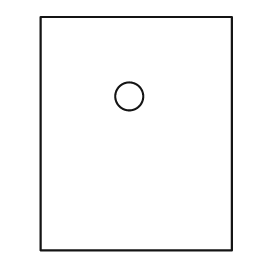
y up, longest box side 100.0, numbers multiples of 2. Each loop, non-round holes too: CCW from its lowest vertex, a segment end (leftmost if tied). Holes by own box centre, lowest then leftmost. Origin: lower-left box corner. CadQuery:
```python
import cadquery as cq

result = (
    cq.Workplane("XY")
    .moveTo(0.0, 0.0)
    .lineTo(82.0, 0.0)
    .lineTo(82.0, 100.0)
    .lineTo(0.0, 100.0)
    .close()
    .moveTo(38.0, 66.0)
    .circle(6.0)
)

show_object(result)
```